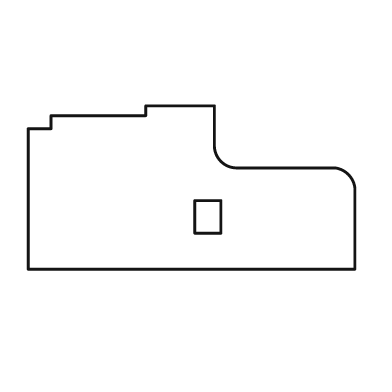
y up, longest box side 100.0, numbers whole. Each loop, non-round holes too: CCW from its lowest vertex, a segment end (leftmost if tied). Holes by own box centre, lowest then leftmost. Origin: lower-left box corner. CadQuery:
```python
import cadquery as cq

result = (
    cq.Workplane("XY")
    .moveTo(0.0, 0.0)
    .lineTo(100.0, 0.0)
    .lineTo(100.0, 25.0)
    .threePointArc((98.0, 29.0), (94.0, 31.0))
    .lineTo(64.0, 31.0)
    .threePointArc((59.0, 33.0), (57.0, 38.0))
    .lineTo(57.0, 50.0)
    .lineTo(36.0, 50.0)
    .lineTo(36.0, 47.0)
    .lineTo(7.0, 47.0)
    .lineTo(7.0, 43.0)
    .lineTo(0.0, 43.0)
    .close()
    .moveTo(51.0, 11.0)
    .lineTo(59.0, 11.0)
    .lineTo(59.0, 21.0)
    .lineTo(51.0, 21.0)
    .close()
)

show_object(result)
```